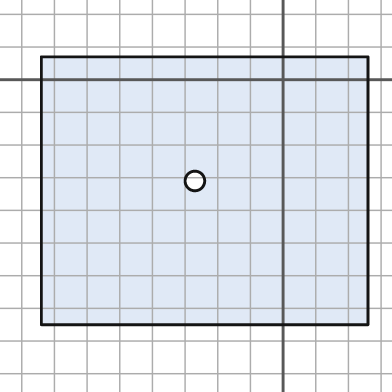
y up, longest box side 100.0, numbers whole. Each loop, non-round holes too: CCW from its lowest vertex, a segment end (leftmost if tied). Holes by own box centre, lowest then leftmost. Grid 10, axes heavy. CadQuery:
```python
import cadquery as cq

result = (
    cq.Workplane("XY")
    .moveTo(-74.0, -75.0)
    .lineTo(26.0, -75.0)
    .lineTo(26.0, 7.0)
    .lineTo(-74.0, 7.0)
    .close()
    .moveTo(-27.0, -31.0)
    .circle(3.0)
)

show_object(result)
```